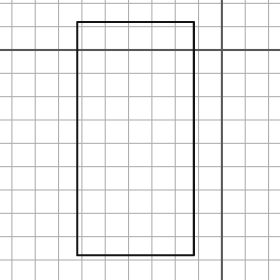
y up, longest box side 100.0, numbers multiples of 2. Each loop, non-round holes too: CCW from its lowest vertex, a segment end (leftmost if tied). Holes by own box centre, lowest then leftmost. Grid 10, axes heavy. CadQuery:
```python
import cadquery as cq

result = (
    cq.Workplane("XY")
    .moveTo(-62.0, -88.0)
    .lineTo(-12.0, -88.0)
    .lineTo(-12.0, 12.0)
    .lineTo(-62.0, 12.0)
    .close()
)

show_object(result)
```